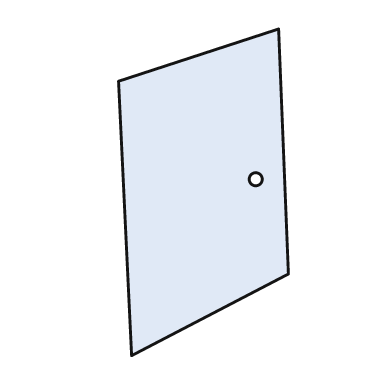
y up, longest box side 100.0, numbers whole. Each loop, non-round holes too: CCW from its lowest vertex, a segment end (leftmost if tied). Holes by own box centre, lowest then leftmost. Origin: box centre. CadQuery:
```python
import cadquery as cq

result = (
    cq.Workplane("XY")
    .moveTo(-22.0, -50.0)
    .lineTo(26.0, -25.0)
    .lineTo(23.0, 50.0)
    .lineTo(-26.0, 34.0)
    .close()
    .moveTo(16.0, 4.0)
    .circle(2.0)
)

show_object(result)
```